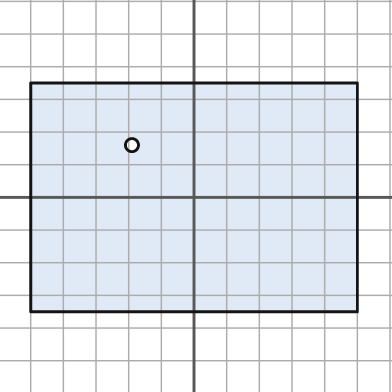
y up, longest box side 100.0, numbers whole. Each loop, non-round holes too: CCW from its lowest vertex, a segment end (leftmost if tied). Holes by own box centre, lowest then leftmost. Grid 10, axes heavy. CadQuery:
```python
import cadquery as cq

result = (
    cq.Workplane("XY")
    .moveTo(-50.0, -35.0)
    .lineTo(50.0, -35.0)
    .lineTo(50.0, 35.0)
    .lineTo(-50.0, 35.0)
    .close()
    .moveTo(-19.0, 16.0)
    .circle(2.0)
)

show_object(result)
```